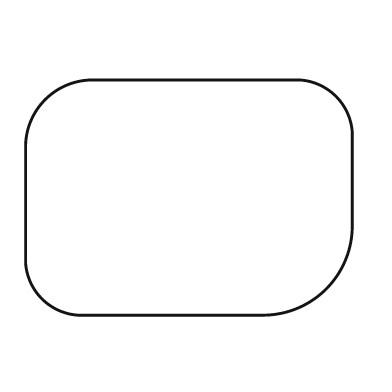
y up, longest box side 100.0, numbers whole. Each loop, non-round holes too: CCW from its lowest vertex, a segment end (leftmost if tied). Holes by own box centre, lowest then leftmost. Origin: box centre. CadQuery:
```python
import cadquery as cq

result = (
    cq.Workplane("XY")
    .moveTo(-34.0, -36.0)
    .lineTo(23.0, -36.0)
    .threePointArc((42.0, -28.0), (50.0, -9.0))
    .lineTo(50.0, 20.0)
    .threePointArc((45.0, 31.0), (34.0, 36.0))
    .lineTo(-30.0, 36.0)
    .threePointArc((-44.0, 30.0), (-50.0, 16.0))
    .lineTo(-50.0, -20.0)
    .threePointArc((-45.0, -31.0), (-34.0, -36.0))
    .close()
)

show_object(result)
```